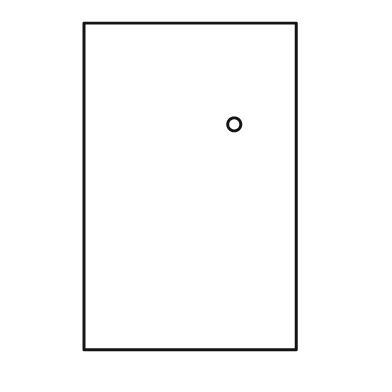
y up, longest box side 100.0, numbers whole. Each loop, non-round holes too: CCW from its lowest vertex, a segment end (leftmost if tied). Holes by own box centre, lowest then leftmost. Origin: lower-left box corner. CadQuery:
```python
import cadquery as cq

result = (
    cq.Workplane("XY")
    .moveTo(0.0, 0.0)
    .lineTo(65.0, 0.0)
    .lineTo(65.0, 100.0)
    .lineTo(0.0, 100.0)
    .close()
    .moveTo(46.0, 69.0)
    .circle(2.0)
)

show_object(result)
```